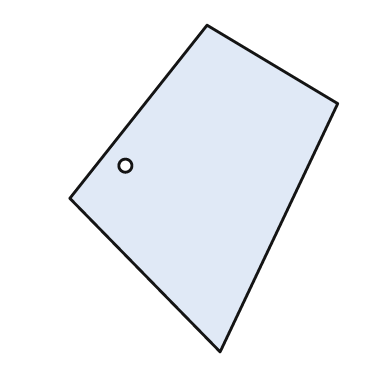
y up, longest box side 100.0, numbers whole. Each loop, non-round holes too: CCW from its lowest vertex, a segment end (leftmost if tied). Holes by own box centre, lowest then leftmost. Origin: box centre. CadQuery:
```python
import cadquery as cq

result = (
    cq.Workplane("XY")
    .moveTo(5.0, -50.0)
    .lineTo(41.0, 26.0)
    .lineTo(1.0, 50.0)
    .lineTo(-41.0, -3.0)
    .close()
    .moveTo(-24.0, 7.0)
    .circle(2.0)
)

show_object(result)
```